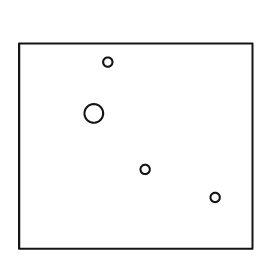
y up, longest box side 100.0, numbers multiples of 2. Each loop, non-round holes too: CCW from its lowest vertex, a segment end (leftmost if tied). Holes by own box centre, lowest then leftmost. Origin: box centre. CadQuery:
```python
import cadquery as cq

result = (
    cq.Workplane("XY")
    .moveTo(-50.0, -44.0)
    .lineTo(50.0, -44.0)
    .lineTo(50.0, 44.0)
    .lineTo(-50.0, 44.0)
    .close()
    .moveTo(34.0, -22.0)
    .circle(2.0)
    .moveTo(4.0, -10.0)
    .circle(2.0)
    .moveTo(-18.0, 14.0)
    .circle(4.0)
    .moveTo(-12.0, 36.0)
    .circle(2.0)
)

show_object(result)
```